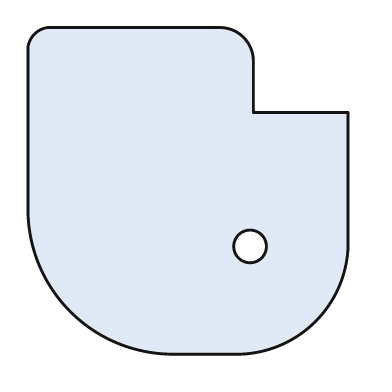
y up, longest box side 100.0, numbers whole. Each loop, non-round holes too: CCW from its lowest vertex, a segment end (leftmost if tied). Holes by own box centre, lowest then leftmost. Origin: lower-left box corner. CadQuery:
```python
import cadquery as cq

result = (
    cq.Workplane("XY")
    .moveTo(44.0, 0.0)
    .lineTo(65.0, 0.0)
    .threePointArc((88.0, 10.0), (98.0, 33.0))
    .lineTo(98.0, 74.0)
    .lineTo(69.0, 74.0)
    .lineTo(69.0, 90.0)
    .threePointArc((66.0, 97.0), (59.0, 100.0))
    .lineTo(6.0, 100.0)
    .threePointArc((2.0, 98.0), (0.0, 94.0))
    .lineTo(0.0, 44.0)
    .threePointArc((13.0, 13.0), (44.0, 0.0))
    .close()
    .moveTo(68.0, 33.0)
    .circle(5.0)
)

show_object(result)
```